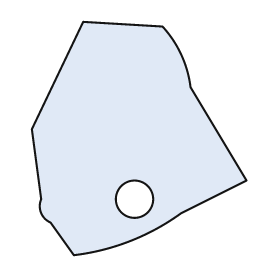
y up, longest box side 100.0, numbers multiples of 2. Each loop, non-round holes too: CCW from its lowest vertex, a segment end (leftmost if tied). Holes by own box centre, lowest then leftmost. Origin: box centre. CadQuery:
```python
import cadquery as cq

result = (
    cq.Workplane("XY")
    .moveTo(-28.0, -50.0)
    .threePointArc((-4.0, -44.0), (18.0, -32.0))
    .lineTo(46.0, -18.0)
    .lineTo(22.0, 22.0)
    .threePointArc((18.0, 36.0), (10.0, 48.0))
    .lineTo(-24.0, 50.0)
    .lineTo(-46.0, 4.0)
    .lineTo(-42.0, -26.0)
    .threePointArc((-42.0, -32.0), (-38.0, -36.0))
    .close()
    .moveTo(-2.0, -26.0)
    .circle(8.0)
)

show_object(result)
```